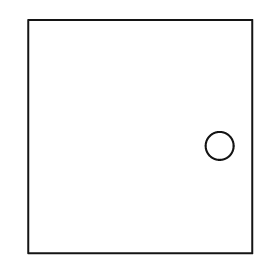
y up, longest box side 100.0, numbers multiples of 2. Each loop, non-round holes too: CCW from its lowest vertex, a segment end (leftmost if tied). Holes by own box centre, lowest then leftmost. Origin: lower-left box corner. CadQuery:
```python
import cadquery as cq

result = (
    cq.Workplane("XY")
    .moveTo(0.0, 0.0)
    .lineTo(96.0, 0.0)
    .lineTo(96.0, 100.0)
    .lineTo(0.0, 100.0)
    .close()
    .moveTo(82.0, 46.0)
    .circle(6.0)
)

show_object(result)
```